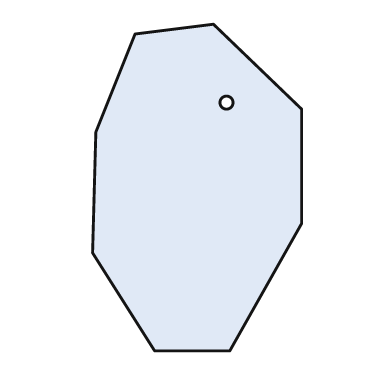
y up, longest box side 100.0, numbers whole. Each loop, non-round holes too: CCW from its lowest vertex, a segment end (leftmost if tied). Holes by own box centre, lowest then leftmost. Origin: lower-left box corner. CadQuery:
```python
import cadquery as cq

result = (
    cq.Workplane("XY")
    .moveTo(19.0, 0.0)
    .lineTo(42.0, 0.0)
    .lineTo(64.0, 39.0)
    .lineTo(64.0, 74.0)
    .lineTo(37.0, 100.0)
    .lineTo(13.0, 97.0)
    .lineTo(1.0, 67.0)
    .lineTo(0.0, 30.0)
    .close()
    .moveTo(41.0, 76.0)
    .circle(2.0)
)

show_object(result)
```